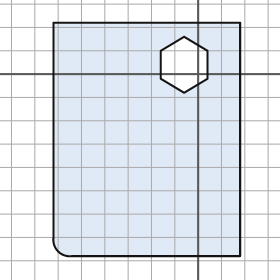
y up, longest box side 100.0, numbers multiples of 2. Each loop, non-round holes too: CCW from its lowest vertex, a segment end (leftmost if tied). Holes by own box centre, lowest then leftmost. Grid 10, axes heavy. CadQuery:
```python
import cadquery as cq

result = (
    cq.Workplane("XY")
    .moveTo(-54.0, -78.0)
    .lineTo(18.0, -78.0)
    .lineTo(18.0, 22.0)
    .lineTo(-62.0, 22.0)
    .lineTo(-62.0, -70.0)
    .threePointArc((-60.0, -76.0), (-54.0, -78.0))
    .close()
    .moveTo(-6.0, -8.0)
    .lineTo(4.0, -2.0)
    .lineTo(4.0, 10.0)
    .lineTo(-6.0, 16.0)
    .lineTo(-16.0, 10.0)
    .lineTo(-16.0, -2.0)
    .close()
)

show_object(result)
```